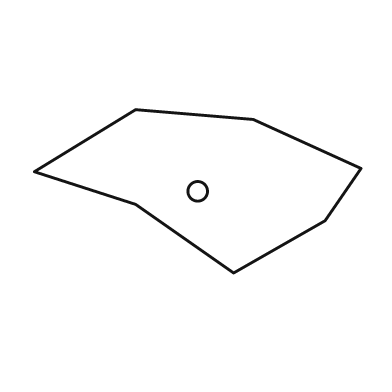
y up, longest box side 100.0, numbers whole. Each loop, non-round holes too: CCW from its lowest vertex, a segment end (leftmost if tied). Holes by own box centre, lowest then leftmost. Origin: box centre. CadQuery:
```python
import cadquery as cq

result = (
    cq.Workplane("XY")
    .moveTo(11.0, -25.0)
    .lineTo(39.0, -9.0)
    .lineTo(50.0, 7.0)
    .lineTo(17.0, 22.0)
    .lineTo(-19.0, 25.0)
    .lineTo(-50.0, 6.0)
    .lineTo(-19.0, -4.0)
    .close()
    .moveTo(0.0, 0.0)
    .circle(3.0)
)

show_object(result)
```